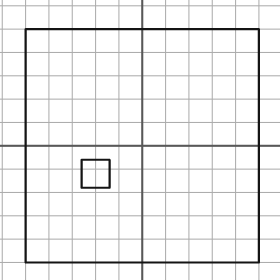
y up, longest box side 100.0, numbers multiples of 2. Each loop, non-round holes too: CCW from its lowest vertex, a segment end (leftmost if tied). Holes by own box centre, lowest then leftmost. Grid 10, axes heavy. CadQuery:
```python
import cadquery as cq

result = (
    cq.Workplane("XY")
    .moveTo(-50.0, -50.0)
    .lineTo(50.0, -50.0)
    .lineTo(50.0, 50.0)
    .lineTo(-50.0, 50.0)
    .close()
    .moveTo(-26.0, -18.0)
    .lineTo(-14.0, -18.0)
    .lineTo(-14.0, -6.0)
    .lineTo(-26.0, -6.0)
    .close()
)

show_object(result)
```